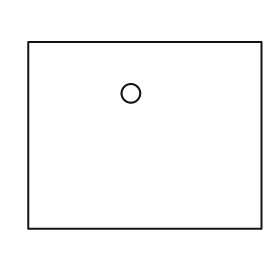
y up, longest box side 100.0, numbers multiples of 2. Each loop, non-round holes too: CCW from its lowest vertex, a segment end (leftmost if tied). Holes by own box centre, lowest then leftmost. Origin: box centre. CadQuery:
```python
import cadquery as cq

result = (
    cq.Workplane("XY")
    .moveTo(-50.0, -40.0)
    .lineTo(50.0, -40.0)
    .lineTo(50.0, 40.0)
    .lineTo(-50.0, 40.0)
    .close()
    .moveTo(-6.0, 18.0)
    .circle(4.0)
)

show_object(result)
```